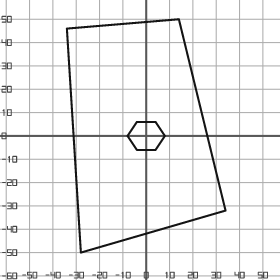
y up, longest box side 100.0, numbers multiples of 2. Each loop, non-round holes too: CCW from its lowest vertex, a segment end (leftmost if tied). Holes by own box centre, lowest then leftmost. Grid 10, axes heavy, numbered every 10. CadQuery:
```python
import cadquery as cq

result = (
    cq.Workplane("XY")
    .moveTo(-28.0, -50.0)
    .lineTo(34.0, -32.0)
    .lineTo(14.0, 50.0)
    .lineTo(-34.0, 46.0)
    .close()
    .moveTo(-4.0, -6.0)
    .lineTo(4.0, -6.0)
    .lineTo(8.0, 0.0)
    .lineTo(4.0, 6.0)
    .lineTo(-4.0, 6.0)
    .lineTo(-8.0, 0.0)
    .close()
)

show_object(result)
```